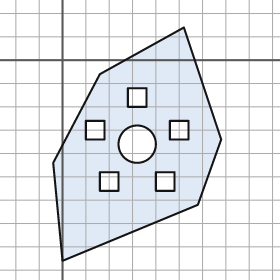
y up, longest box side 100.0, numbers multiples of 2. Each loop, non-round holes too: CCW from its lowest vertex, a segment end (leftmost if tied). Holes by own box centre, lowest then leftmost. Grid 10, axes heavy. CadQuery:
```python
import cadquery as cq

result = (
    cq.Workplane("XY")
    .moveTo(0.0, -86.0)
    .lineTo(58.0, -62.0)
    .lineTo(68.0, -34.0)
    .lineTo(52.0, 14.0)
    .lineTo(16.0, -6.0)
    .lineTo(-4.0, -44.0)
    .close()
    .moveTo(16.0, -56.0)
    .lineTo(24.0, -56.0)
    .lineTo(24.0, -48.0)
    .lineTo(16.0, -48.0)
    .close()
    .moveTo(40.0, -56.0)
    .lineTo(48.0, -56.0)
    .lineTo(48.0, -48.0)
    .lineTo(40.0, -48.0)
    .close()
    .moveTo(32.0, -36.0)
    .circle(8.0)
    .moveTo(10.0, -34.0)
    .lineTo(18.0, -34.0)
    .lineTo(18.0, -26.0)
    .lineTo(10.0, -26.0)
    .close()
    .moveTo(46.0, -34.0)
    .lineTo(54.0, -34.0)
    .lineTo(54.0, -26.0)
    .lineTo(46.0, -26.0)
    .close()
    .moveTo(28.0, -20.0)
    .lineTo(36.0, -20.0)
    .lineTo(36.0, -12.0)
    .lineTo(28.0, -12.0)
    .close()
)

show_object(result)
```